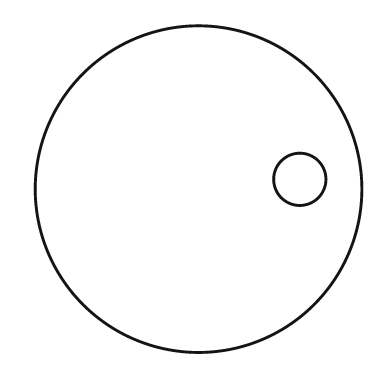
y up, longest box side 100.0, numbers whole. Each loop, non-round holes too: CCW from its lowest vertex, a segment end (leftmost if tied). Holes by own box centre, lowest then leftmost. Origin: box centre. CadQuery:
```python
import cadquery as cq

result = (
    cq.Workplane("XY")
    .moveTo(0.0, 0.0)
    .circle(50.0)
    .moveTo(31.0, 3.0)
    .circle(8.0)
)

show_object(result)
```